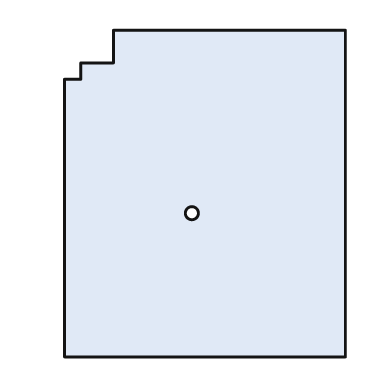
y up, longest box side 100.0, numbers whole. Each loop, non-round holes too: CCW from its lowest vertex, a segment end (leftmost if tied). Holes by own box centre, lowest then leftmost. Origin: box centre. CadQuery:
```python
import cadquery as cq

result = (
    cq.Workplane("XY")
    .moveTo(-43.0, -50.0)
    .lineTo(43.0, -50.0)
    .lineTo(43.0, 50.0)
    .lineTo(-28.0, 50.0)
    .lineTo(-28.0, 40.0)
    .lineTo(-38.0, 40.0)
    .lineTo(-38.0, 35.0)
    .lineTo(-43.0, 35.0)
    .close()
    .moveTo(-4.0, -6.0)
    .circle(2.0)
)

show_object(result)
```